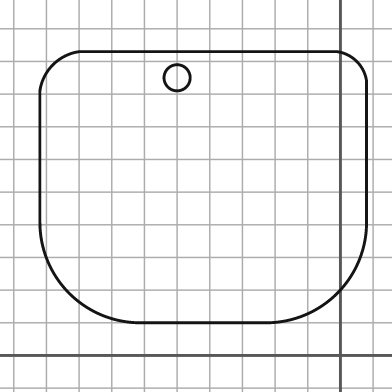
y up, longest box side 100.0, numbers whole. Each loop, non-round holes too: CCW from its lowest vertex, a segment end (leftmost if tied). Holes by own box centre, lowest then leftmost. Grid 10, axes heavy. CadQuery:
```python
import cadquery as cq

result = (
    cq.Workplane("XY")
    .moveTo(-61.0, 10.0)
    .lineTo(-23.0, 10.0)
    .threePointArc((-1.0, 19.0), (8.0, 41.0))
    .lineTo(8.0, 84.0)
    .threePointArc((5.0, 90.0), (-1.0, 93.0))
    .lineTo(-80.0, 93.0)
    .threePointArc((-88.0, 89.0), (-92.0, 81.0))
    .lineTo(-92.0, 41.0)
    .threePointArc((-83.0, 19.0), (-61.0, 10.0))
    .close()
    .moveTo(-50.0, 85.0)
    .circle(4.0)
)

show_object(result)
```